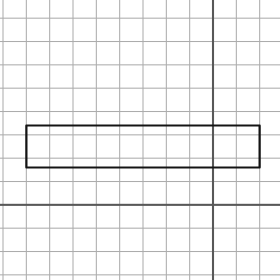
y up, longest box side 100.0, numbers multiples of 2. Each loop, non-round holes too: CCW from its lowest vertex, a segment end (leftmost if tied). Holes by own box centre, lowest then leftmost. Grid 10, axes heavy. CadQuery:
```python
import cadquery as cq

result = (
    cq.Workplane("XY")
    .moveTo(-80.0, 16.0)
    .lineTo(20.0, 16.0)
    .lineTo(20.0, 34.0)
    .lineTo(-80.0, 34.0)
    .close()
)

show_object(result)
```